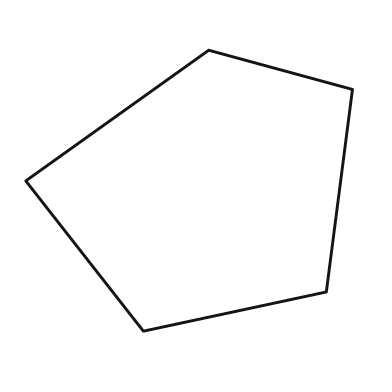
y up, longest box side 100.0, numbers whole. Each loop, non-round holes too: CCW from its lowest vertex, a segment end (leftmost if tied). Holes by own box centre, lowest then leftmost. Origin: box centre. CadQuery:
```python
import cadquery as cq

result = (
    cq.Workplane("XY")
    .moveTo(-14.0, -43.0)
    .lineTo(42.0, -31.0)
    .lineTo(50.0, 31.0)
    .lineTo(6.0, 43.0)
    .lineTo(-50.0, 3.0)
    .close()
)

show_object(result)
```